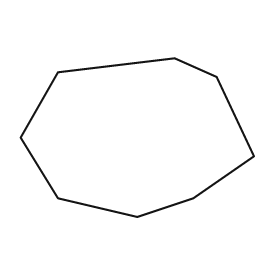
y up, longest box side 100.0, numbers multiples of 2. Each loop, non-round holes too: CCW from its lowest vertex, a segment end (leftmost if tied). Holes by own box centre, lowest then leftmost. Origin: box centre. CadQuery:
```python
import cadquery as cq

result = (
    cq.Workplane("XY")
    .moveTo(0.0, -34.0)
    .lineTo(24.0, -26.0)
    .lineTo(50.0, -8.0)
    .lineTo(34.0, 26.0)
    .lineTo(16.0, 34.0)
    .lineTo(-34.0, 28.0)
    .lineTo(-50.0, 0.0)
    .lineTo(-34.0, -26.0)
    .close()
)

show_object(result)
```